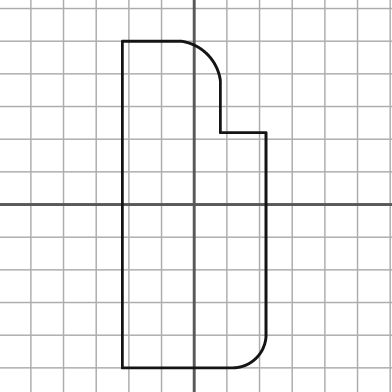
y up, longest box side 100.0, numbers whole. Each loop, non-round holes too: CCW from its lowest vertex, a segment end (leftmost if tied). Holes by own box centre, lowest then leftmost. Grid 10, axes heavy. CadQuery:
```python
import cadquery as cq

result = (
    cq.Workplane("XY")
    .moveTo(-22.0, -50.0)
    .lineTo(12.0, -50.0)
    .threePointArc((19.0, -47.0), (22.0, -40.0))
    .lineTo(22.0, 22.0)
    .lineTo(8.0, 22.0)
    .lineTo(8.0, 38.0)
    .threePointArc((4.0, 46.0), (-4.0, 50.0))
    .lineTo(-22.0, 50.0)
    .close()
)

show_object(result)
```